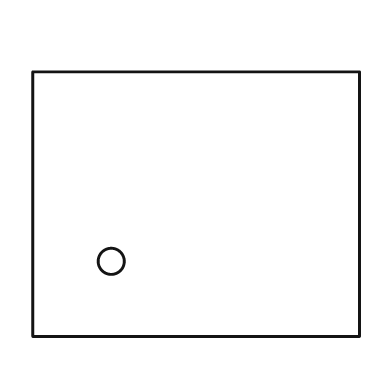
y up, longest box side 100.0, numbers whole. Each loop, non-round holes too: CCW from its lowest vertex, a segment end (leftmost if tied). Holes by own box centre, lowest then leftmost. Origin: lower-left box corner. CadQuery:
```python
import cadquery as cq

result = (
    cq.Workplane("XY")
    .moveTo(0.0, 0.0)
    .lineTo(100.0, 0.0)
    .lineTo(100.0, 81.0)
    .lineTo(0.0, 81.0)
    .close()
    .moveTo(24.0, 23.0)
    .circle(4.0)
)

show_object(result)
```